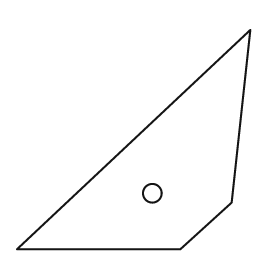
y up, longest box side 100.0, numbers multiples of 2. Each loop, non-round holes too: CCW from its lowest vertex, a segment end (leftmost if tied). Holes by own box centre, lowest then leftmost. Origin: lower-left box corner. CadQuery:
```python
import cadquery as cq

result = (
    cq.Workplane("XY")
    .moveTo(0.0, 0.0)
    .lineTo(70.0, 0.0)
    .lineTo(92.0, 20.0)
    .lineTo(100.0, 94.0)
    .close()
    .moveTo(58.0, 24.0)
    .circle(4.0)
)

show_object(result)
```